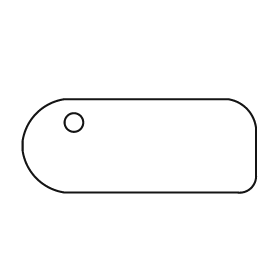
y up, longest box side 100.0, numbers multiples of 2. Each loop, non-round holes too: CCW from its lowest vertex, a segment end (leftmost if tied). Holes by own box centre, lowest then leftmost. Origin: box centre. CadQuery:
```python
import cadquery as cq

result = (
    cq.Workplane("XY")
    .moveTo(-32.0, -20.0)
    .lineTo(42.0, -20.0)
    .threePointArc((48.0, -18.0), (50.0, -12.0))
    .lineTo(50.0, 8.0)
    .threePointArc((46.0, 16.0), (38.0, 20.0))
    .lineTo(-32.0, 20.0)
    .threePointArc((-44.0, 14.0), (-50.0, 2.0))
    .lineTo(-50.0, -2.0)
    .threePointArc((-44.0, -14.0), (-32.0, -20.0))
    .close()
    .moveTo(-28.0, 10.0)
    .circle(4.0)
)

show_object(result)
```